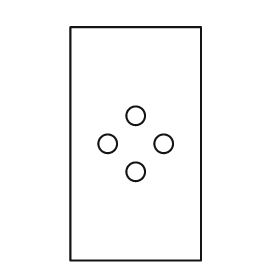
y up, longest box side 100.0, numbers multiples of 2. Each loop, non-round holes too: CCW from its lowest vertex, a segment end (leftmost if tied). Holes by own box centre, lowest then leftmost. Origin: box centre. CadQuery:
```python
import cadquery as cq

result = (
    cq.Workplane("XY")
    .moveTo(-28.0, -50.0)
    .lineTo(28.0, -50.0)
    .lineTo(28.0, 50.0)
    .lineTo(-28.0, 50.0)
    .close()
    .moveTo(0.0, -12.0)
    .circle(4.0)
    .moveTo(-12.0, 0.0)
    .circle(4.0)
    .moveTo(12.0, 0.0)
    .circle(4.0)
    .moveTo(0.0, 12.0)
    .circle(4.0)
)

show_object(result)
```